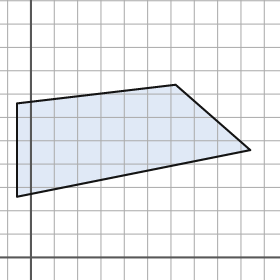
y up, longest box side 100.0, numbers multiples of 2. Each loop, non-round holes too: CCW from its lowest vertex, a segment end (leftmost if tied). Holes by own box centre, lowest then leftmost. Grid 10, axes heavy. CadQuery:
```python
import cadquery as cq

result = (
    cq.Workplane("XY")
    .moveTo(-6.0, 26.0)
    .lineTo(94.0, 46.0)
    .lineTo(62.0, 74.0)
    .lineTo(-6.0, 66.0)
    .close()
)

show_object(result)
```